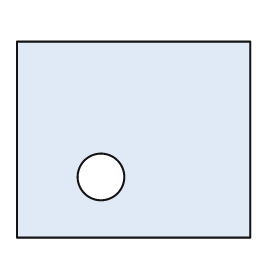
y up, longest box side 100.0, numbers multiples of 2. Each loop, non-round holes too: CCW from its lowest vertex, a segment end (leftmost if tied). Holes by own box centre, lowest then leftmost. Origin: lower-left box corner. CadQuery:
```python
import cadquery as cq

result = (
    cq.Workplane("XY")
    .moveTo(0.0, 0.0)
    .lineTo(100.0, 0.0)
    .lineTo(100.0, 84.0)
    .lineTo(0.0, 84.0)
    .close()
    .moveTo(36.0, 26.0)
    .circle(10.0)
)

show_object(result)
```